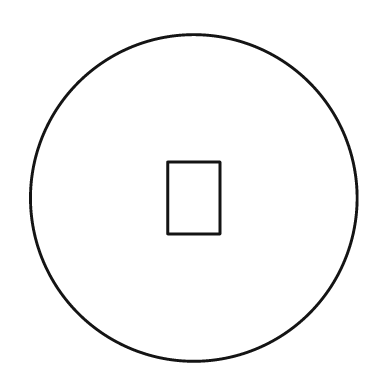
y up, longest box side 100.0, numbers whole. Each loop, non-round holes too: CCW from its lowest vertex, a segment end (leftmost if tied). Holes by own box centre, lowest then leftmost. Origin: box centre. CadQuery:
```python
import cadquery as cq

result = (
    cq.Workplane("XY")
    .moveTo(0.0, 0.0)
    .circle(50.0)
    .moveTo(-8.0, -11.0)
    .lineTo(8.0, -11.0)
    .lineTo(8.0, 11.0)
    .lineTo(-8.0, 11.0)
    .close()
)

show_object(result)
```